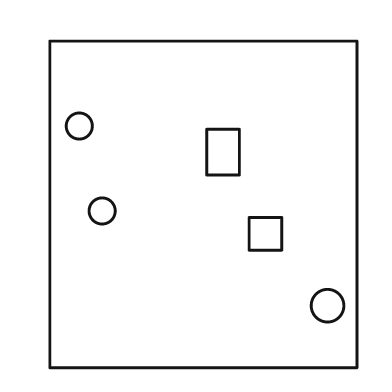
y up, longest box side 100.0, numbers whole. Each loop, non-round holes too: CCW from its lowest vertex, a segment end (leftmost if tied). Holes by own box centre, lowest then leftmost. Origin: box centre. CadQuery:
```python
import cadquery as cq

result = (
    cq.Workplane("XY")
    .moveTo(-47.0, -50.0)
    .lineTo(47.0, -50.0)
    .lineTo(47.0, 50.0)
    .lineTo(-47.0, 50.0)
    .close()
    .moveTo(38.0, -31.0)
    .circle(5.0)
    .moveTo(14.0, -14.0)
    .lineTo(24.0, -14.0)
    .lineTo(24.0, -4.0)
    .lineTo(14.0, -4.0)
    .close()
    .moveTo(-31.0, -2.0)
    .circle(4.0)
    .moveTo(1.0, 9.0)
    .lineTo(11.0, 9.0)
    .lineTo(11.0, 23.0)
    .lineTo(1.0, 23.0)
    .close()
    .moveTo(-38.0, 24.0)
    .circle(4.0)
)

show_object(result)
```